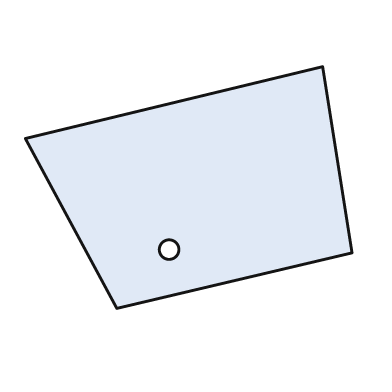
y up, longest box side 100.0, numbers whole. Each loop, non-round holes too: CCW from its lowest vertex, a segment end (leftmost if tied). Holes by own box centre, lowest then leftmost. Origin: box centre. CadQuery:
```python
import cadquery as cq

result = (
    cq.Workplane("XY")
    .moveTo(-22.0, -37.0)
    .lineTo(50.0, -20.0)
    .lineTo(41.0, 37.0)
    .lineTo(-50.0, 15.0)
    .close()
    .moveTo(-6.0, -19.0)
    .circle(3.0)
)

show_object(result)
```